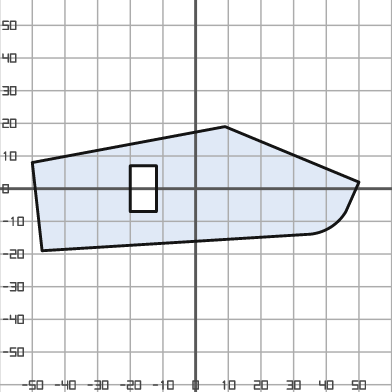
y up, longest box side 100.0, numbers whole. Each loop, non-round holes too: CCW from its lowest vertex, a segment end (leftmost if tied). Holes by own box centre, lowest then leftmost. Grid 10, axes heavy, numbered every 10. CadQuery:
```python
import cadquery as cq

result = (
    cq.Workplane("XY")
    .moveTo(-47.0, -19.0)
    .lineTo(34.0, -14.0)
    .threePointArc((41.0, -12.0), (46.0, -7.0))
    .lineTo(50.0, 2.0)
    .lineTo(9.0, 19.0)
    .lineTo(-50.0, 8.0)
    .close()
    .moveTo(-20.0, -7.0)
    .lineTo(-12.0, -7.0)
    .lineTo(-12.0, 7.0)
    .lineTo(-20.0, 7.0)
    .close()
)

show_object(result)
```